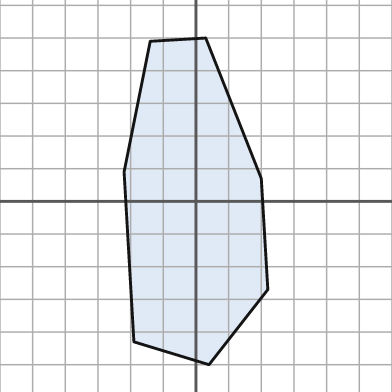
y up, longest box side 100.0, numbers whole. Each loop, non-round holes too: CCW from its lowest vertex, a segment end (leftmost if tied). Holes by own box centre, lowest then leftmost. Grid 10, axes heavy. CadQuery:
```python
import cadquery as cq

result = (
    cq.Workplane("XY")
    .moveTo(4.0, -50.0)
    .lineTo(22.0, -27.0)
    .lineTo(20.0, 7.0)
    .lineTo(3.0, 50.0)
    .lineTo(-14.0, 49.0)
    .lineTo(-22.0, 9.0)
    .lineTo(-19.0, -43.0)
    .close()
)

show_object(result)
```